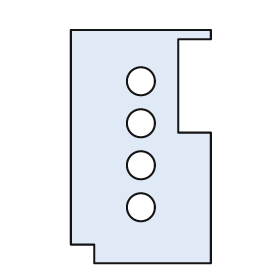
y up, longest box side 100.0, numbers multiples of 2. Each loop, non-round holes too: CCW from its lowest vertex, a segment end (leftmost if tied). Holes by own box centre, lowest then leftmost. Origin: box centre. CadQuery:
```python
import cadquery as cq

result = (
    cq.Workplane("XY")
    .moveTo(-20.0, -50.0)
    .lineTo(30.0, -50.0)
    .lineTo(30.0, 6.0)
    .lineTo(16.0, 6.0)
    .lineTo(16.0, 46.0)
    .lineTo(30.0, 46.0)
    .lineTo(30.0, 50.0)
    .lineTo(-30.0, 50.0)
    .lineTo(-30.0, -42.0)
    .lineTo(-20.0, -42.0)
    .close()
    .moveTo(0.0, -26.0)
    .circle(6.0)
    .moveTo(0.0, -8.0)
    .circle(6.0)
    .moveTo(0.0, 10.0)
    .circle(6.0)
    .moveTo(0.0, 28.0)
    .circle(6.0)
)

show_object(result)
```